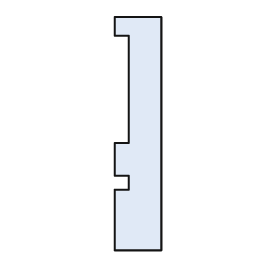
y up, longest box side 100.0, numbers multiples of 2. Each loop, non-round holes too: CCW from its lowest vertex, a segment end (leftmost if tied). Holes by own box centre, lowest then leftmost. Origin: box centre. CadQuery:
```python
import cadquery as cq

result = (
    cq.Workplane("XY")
    .moveTo(-10.0, -50.0)
    .lineTo(10.0, -50.0)
    .lineTo(10.0, 50.0)
    .lineTo(-10.0, 50.0)
    .lineTo(-10.0, 42.0)
    .lineTo(-4.0, 42.0)
    .lineTo(-4.0, -4.0)
    .lineTo(-10.0, -4.0)
    .lineTo(-10.0, -18.0)
    .lineTo(-4.0, -18.0)
    .lineTo(-4.0, -24.0)
    .lineTo(-10.0, -24.0)
    .close()
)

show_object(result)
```